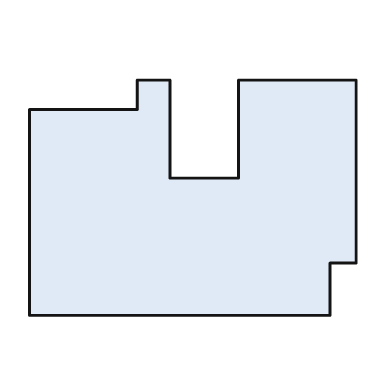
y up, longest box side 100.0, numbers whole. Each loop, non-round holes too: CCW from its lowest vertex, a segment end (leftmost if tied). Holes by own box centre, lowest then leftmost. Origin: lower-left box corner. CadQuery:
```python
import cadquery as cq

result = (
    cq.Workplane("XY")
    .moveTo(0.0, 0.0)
    .lineTo(92.0, 0.0)
    .lineTo(92.0, 16.0)
    .lineTo(100.0, 16.0)
    .lineTo(100.0, 72.0)
    .lineTo(64.0, 72.0)
    .lineTo(64.0, 42.0)
    .lineTo(43.0, 42.0)
    .lineTo(43.0, 72.0)
    .lineTo(33.0, 72.0)
    .lineTo(33.0, 63.0)
    .lineTo(0.0, 63.0)
    .close()
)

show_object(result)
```